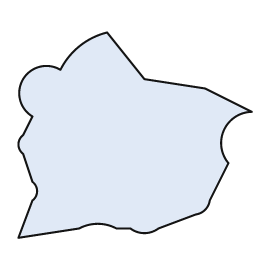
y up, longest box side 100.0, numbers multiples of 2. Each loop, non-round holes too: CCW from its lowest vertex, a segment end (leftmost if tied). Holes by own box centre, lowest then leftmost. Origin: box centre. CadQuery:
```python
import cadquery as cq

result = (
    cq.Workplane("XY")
    .moveTo(-50.0, -44.0)
    .lineTo(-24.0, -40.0)
    .threePointArc((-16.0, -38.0), (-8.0, -40.0))
    .lineTo(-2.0, -40.0)
    .threePointArc((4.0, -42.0), (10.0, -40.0))
    .lineTo(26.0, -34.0)
    .threePointArc((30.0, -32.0), (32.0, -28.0))
    .lineTo(40.0, -12.0)
    .threePointArc((38.0, 2.0), (50.0, 10.0))
    .lineTo(30.0, 20.0)
    .lineTo(4.0, 24.0)
    .lineTo(-12.0, 44.0)
    .threePointArc((-24.0, 38.0), (-32.0, 28.0))
    .threePointArc((-48.0, 24.0), (-44.0, 8.0))
    .lineTo(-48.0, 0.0)
    .threePointArc((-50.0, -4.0), (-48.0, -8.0))
    .lineTo(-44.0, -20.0)
    .threePointArc((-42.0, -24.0), (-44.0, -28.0))
    .close()
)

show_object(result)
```